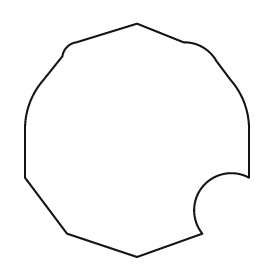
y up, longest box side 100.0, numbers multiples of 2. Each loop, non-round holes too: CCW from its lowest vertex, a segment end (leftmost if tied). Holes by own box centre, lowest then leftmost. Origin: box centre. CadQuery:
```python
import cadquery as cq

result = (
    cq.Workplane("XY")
    .moveTo(0.0, -50.0)
    .lineTo(28.0, -40.0)
    .threePointArc((28.0, -20.0), (48.0, -16.0))
    .lineTo(48.0, 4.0)
    .threePointArc((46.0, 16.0), (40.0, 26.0))
    .lineTo(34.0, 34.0)
    .threePointArc((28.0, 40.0), (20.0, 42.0))
    .lineTo(0.0, 50.0)
    .lineTo(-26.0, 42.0)
    .threePointArc((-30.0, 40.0), (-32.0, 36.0))
    .lineTo(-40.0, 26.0)
    .threePointArc((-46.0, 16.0), (-48.0, 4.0))
    .lineTo(-48.0, -16.0)
    .lineTo(-30.0, -40.0)
    .close()
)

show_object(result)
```